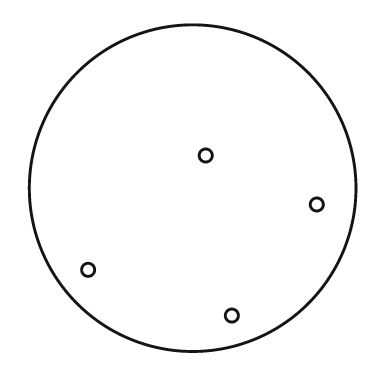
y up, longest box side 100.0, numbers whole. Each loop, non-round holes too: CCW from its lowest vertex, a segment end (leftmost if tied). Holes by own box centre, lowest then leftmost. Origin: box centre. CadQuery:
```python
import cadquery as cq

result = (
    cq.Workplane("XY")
    .moveTo(0.0, 0.0)
    .circle(50.0)
    .moveTo(12.0, -39.0)
    .circle(2.0)
    .moveTo(-32.0, -25.0)
    .circle(2.0)
    .moveTo(38.0, -5.0)
    .circle(2.0)
    .moveTo(4.0, 10.0)
    .circle(2.0)
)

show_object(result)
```